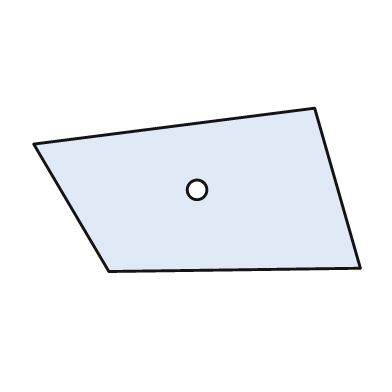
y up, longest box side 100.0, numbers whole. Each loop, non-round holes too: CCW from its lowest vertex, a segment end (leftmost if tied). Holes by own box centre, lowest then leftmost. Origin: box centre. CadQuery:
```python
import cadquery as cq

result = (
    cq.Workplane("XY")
    .moveTo(-27.0, -25.0)
    .lineTo(50.0, -24.0)
    .lineTo(36.0, 25.0)
    .lineTo(-50.0, 14.0)
    .close()
    .moveTo(0.0, 0.0)
    .circle(3.0)
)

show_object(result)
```